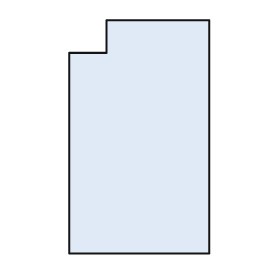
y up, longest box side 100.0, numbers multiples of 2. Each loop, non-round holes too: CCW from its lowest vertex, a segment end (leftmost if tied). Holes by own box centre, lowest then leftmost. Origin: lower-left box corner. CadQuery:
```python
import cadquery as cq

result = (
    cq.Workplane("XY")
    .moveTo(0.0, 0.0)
    .lineTo(60.0, 0.0)
    .lineTo(60.0, 100.0)
    .lineTo(16.0, 100.0)
    .lineTo(16.0, 86.0)
    .lineTo(0.0, 86.0)
    .close()
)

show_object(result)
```